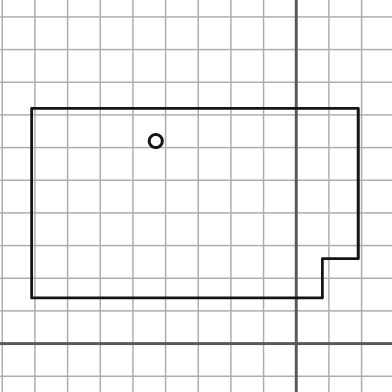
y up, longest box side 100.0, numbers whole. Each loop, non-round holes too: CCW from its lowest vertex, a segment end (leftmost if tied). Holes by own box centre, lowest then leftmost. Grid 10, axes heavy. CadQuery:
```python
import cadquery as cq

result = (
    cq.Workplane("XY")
    .moveTo(-81.0, 14.0)
    .lineTo(8.0, 14.0)
    .lineTo(8.0, 26.0)
    .lineTo(19.0, 26.0)
    .lineTo(19.0, 72.0)
    .lineTo(-81.0, 72.0)
    .close()
    .moveTo(-43.0, 62.0)
    .circle(2.0)
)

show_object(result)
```